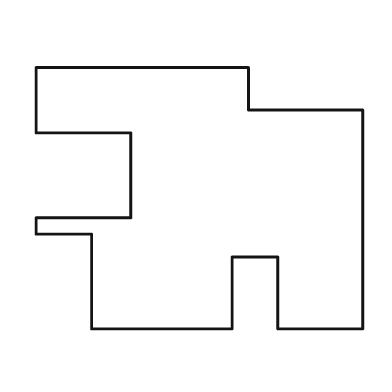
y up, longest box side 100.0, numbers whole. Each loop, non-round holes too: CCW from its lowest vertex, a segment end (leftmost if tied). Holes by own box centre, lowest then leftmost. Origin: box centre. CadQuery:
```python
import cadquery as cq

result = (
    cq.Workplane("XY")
    .moveTo(-33.0, -40.0)
    .lineTo(10.0, -40.0)
    .lineTo(10.0, -18.0)
    .lineTo(24.0, -18.0)
    .lineTo(24.0, -40.0)
    .lineTo(50.0, -40.0)
    .lineTo(50.0, 27.0)
    .lineTo(15.0, 27.0)
    .lineTo(15.0, 40.0)
    .lineTo(-50.0, 40.0)
    .lineTo(-50.0, 20.0)
    .lineTo(-21.0, 20.0)
    .lineTo(-21.0, -6.0)
    .lineTo(-50.0, -6.0)
    .lineTo(-50.0, -11.0)
    .lineTo(-33.0, -11.0)
    .close()
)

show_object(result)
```